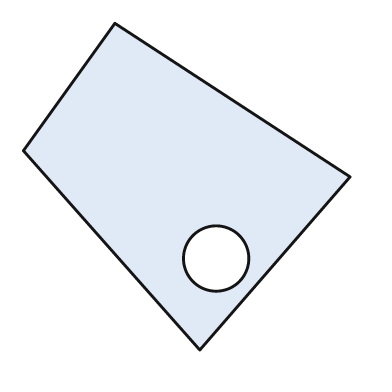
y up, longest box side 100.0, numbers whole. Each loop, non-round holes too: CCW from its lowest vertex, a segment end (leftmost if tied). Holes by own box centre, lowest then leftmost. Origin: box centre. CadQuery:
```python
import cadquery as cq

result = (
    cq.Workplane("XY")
    .moveTo(4.0, -50.0)
    .lineTo(50.0, 3.0)
    .lineTo(-22.0, 50.0)
    .lineTo(-50.0, 11.0)
    .close()
    .moveTo(9.0, -22.0)
    .circle(10.0)
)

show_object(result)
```